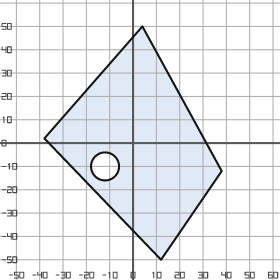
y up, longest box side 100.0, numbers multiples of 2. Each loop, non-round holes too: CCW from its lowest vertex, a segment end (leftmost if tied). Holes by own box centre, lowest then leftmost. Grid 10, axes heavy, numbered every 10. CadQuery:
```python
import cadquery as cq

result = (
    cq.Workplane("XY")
    .moveTo(12.0, -50.0)
    .lineTo(38.0, -12.0)
    .lineTo(4.0, 50.0)
    .lineTo(-38.0, 2.0)
    .close()
    .moveTo(-12.0, -10.0)
    .circle(6.0)
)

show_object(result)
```